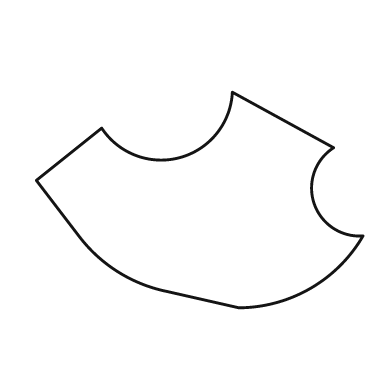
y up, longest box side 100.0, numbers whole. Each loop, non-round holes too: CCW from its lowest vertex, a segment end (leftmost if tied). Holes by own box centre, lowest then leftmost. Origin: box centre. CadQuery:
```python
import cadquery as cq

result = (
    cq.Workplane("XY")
    .moveTo(12.0, -33.0)
    .threePointArc((34.0, -27.0), (50.0, -11.0))
    .threePointArc((35.0, -1.0), (41.0, 16.0))
    .lineTo(10.0, 33.0)
    .threePointArc((-6.0, 13.0), (-30.0, 22.0))
    .lineTo(-50.0, 6.0)
    .lineTo(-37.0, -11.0)
    .threePointArc((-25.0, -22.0), (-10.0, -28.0))
    .close()
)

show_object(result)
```